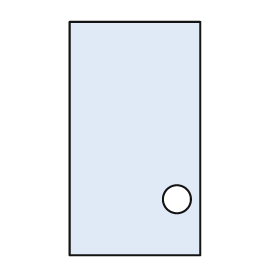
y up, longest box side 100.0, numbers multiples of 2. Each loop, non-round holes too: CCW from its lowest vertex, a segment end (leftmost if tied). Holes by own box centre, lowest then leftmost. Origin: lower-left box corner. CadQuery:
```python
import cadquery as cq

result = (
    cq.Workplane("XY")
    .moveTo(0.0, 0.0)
    .lineTo(56.0, 0.0)
    .lineTo(56.0, 100.0)
    .lineTo(0.0, 100.0)
    .close()
    .moveTo(46.0, 24.0)
    .circle(6.0)
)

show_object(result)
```